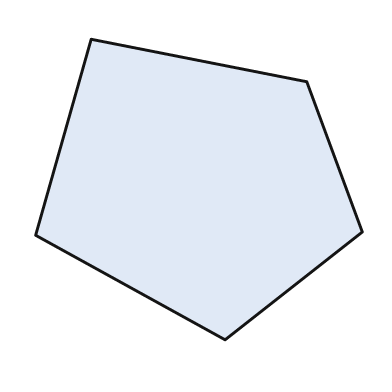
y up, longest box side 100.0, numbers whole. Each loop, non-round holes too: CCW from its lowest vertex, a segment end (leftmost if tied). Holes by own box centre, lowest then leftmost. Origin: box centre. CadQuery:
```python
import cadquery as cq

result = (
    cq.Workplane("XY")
    .moveTo(8.0, -46.0)
    .lineTo(50.0, -13.0)
    .lineTo(33.0, 33.0)
    .lineTo(-33.0, 46.0)
    .lineTo(-50.0, -14.0)
    .close()
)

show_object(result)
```